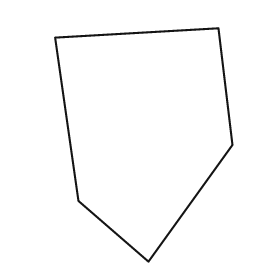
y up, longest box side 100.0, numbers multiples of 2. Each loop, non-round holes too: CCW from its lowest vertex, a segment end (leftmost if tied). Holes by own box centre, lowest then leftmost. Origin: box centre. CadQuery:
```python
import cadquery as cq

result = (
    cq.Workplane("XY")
    .moveTo(2.0, -50.0)
    .lineTo(38.0, 0.0)
    .lineTo(32.0, 50.0)
    .lineTo(-38.0, 46.0)
    .lineTo(-28.0, -24.0)
    .close()
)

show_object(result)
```